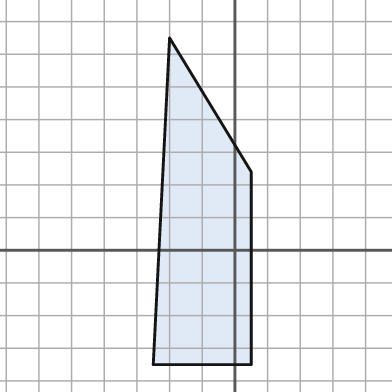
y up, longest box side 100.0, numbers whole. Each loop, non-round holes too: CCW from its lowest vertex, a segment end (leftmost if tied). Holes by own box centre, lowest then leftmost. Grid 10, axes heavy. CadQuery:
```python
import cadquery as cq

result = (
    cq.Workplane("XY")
    .moveTo(-25.0, -35.0)
    .lineTo(5.0, -35.0)
    .lineTo(5.0, 24.0)
    .lineTo(-20.0, 65.0)
    .close()
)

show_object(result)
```